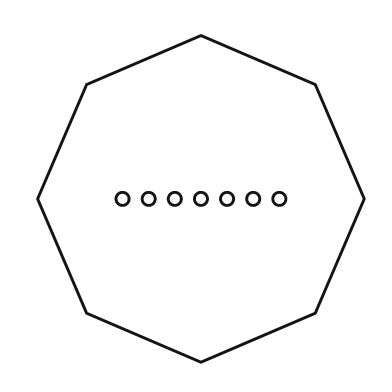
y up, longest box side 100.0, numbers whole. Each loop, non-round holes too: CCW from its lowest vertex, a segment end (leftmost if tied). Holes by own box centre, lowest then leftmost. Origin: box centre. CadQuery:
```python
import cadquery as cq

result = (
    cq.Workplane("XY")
    .moveTo(0.0, -50.0)
    .lineTo(35.0, -35.0)
    .lineTo(50.0, 0.0)
    .lineTo(35.0, 35.0)
    .lineTo(0.0, 50.0)
    .lineTo(-35.0, 35.0)
    .lineTo(-50.0, 0.0)
    .lineTo(-35.0, -35.0)
    .close()
    .moveTo(-24.0, 0.0)
    .circle(2.0)
    .moveTo(-16.0, 0.0)
    .circle(2.0)
    .moveTo(-8.0, 0.0)
    .circle(2.0)
    .moveTo(0.0, 0.0)
    .circle(2.0)
    .moveTo(8.0, 0.0)
    .circle(2.0)
    .moveTo(16.0, 0.0)
    .circle(2.0)
    .moveTo(24.0, 0.0)
    .circle(2.0)
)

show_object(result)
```